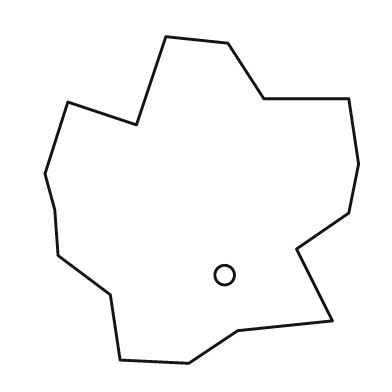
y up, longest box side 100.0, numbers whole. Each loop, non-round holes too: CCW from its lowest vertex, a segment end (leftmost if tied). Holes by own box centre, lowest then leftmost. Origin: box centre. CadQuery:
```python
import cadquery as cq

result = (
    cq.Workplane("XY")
    .moveTo(-4.0, -50.0)
    .lineTo(11.0, -40.0)
    .lineTo(40.0, -37.0)
    .lineTo(29.0, -15.0)
    .lineTo(45.0, -4.0)
    .lineTo(48.0, 11.0)
    .lineTo(45.0, 31.0)
    .lineTo(19.0, 31.0)
    .lineTo(8.0, 48.0)
    .lineTo(-11.0, 50.0)
    .lineTo(-20.0, 23.0)
    .lineTo(-41.0, 30.0)
    .lineTo(-48.0, 8.0)
    .lineTo(-45.0, -3.0)
    .lineTo(-44.0, -17.0)
    .lineTo(-28.0, -29.0)
    .lineTo(-25.0, -49.0)
    .close()
    .moveTo(7.0, -23.0)
    .circle(3.0)
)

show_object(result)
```